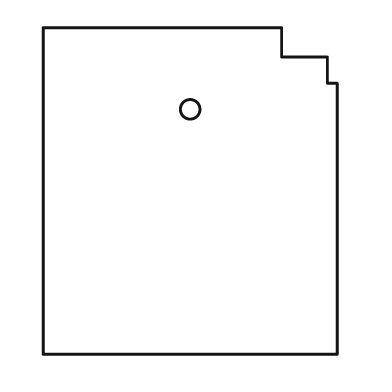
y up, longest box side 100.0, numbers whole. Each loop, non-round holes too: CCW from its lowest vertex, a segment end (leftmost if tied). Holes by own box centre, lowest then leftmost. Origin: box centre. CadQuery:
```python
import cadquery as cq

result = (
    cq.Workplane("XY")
    .moveTo(-45.0, -50.0)
    .lineTo(45.0, -50.0)
    .lineTo(45.0, 33.0)
    .lineTo(42.0, 33.0)
    .lineTo(42.0, 41.0)
    .lineTo(28.0, 41.0)
    .lineTo(28.0, 50.0)
    .lineTo(-45.0, 50.0)
    .close()
    .moveTo(0.0, 25.0)
    .circle(3.0)
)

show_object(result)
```